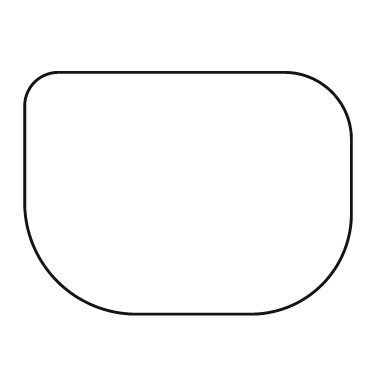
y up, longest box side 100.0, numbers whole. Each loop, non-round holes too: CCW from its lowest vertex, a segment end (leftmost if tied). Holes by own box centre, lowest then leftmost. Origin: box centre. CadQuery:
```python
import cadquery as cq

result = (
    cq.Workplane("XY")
    .moveTo(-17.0, -37.0)
    .lineTo(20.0, -37.0)
    .threePointArc((41.0, -28.0), (50.0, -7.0))
    .lineTo(50.0, 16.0)
    .threePointArc((44.0, 31.0), (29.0, 37.0))
    .lineTo(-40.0, 37.0)
    .threePointArc((-47.0, 34.0), (-50.0, 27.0))
    .lineTo(-50.0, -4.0)
    .threePointArc((-40.0, -27.0), (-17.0, -37.0))
    .close()
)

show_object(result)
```